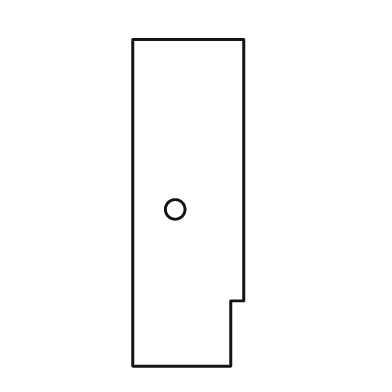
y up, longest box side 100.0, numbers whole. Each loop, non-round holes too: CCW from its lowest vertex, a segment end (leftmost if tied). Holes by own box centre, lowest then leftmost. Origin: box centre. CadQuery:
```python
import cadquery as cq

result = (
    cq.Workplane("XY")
    .moveTo(-17.0, -50.0)
    .lineTo(13.0, -50.0)
    .lineTo(13.0, -30.0)
    .lineTo(17.0, -30.0)
    .lineTo(17.0, 50.0)
    .lineTo(-17.0, 50.0)
    .close()
    .moveTo(-4.0, -2.0)
    .circle(3.0)
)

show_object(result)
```